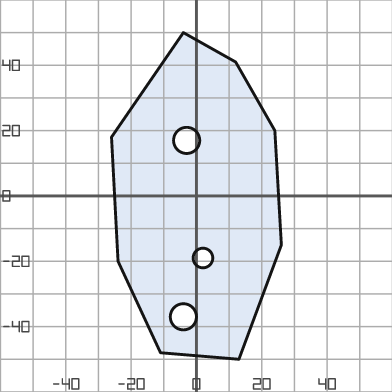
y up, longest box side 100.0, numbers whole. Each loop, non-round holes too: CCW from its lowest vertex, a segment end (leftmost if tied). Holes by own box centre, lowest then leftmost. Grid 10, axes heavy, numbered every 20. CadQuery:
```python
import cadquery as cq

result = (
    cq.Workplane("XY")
    .moveTo(13.0, -50.0)
    .lineTo(26.0, -15.0)
    .lineTo(24.0, 20.0)
    .lineTo(12.0, 41.0)
    .lineTo(-4.0, 50.0)
    .lineTo(-26.0, 18.0)
    .lineTo(-24.0, -20.0)
    .lineTo(-11.0, -48.0)
    .close()
    .moveTo(-4.0, -37.0)
    .circle(4.0)
    .moveTo(2.0, -19.0)
    .circle(3.0)
    .moveTo(-3.0, 17.0)
    .circle(4.0)
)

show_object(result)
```